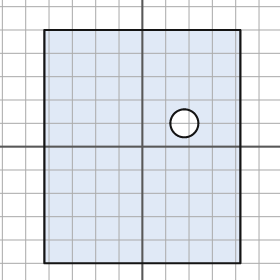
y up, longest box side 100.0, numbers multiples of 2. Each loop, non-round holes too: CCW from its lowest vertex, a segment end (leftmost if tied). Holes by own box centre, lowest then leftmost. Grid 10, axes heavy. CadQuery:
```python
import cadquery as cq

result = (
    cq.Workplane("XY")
    .moveTo(-42.0, -50.0)
    .lineTo(42.0, -50.0)
    .lineTo(42.0, 50.0)
    .lineTo(-42.0, 50.0)
    .close()
    .moveTo(18.0, 10.0)
    .circle(6.0)
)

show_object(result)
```